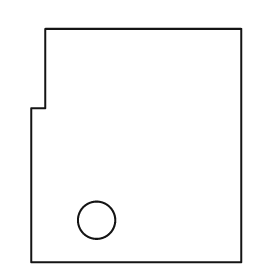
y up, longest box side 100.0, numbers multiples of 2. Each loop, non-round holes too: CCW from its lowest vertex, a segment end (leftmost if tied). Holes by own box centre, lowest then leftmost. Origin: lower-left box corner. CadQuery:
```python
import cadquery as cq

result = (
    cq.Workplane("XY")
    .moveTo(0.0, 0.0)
    .lineTo(90.0, 0.0)
    .lineTo(90.0, 100.0)
    .lineTo(6.0, 100.0)
    .lineTo(6.0, 66.0)
    .lineTo(0.0, 66.0)
    .close()
    .moveTo(28.0, 18.0)
    .circle(8.0)
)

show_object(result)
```